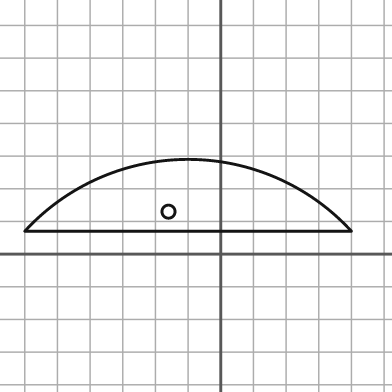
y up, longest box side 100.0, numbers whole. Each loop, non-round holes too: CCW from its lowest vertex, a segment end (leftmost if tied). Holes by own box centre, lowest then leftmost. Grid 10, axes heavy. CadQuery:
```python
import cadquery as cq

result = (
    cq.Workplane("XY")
    .moveTo(-60.0, 7.0)
    .lineTo(40.0, 7.0)
    .threePointArc((-10.0, 29.0), (-60.0, 7.0))
    .close()
    .moveTo(-16.0, 13.0)
    .circle(2.0)
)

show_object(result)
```